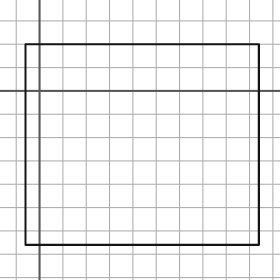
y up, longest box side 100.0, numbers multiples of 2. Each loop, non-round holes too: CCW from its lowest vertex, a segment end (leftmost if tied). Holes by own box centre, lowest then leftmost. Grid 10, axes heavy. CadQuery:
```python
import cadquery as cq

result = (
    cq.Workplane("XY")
    .moveTo(-6.0, -66.0)
    .lineTo(94.0, -66.0)
    .lineTo(94.0, 20.0)
    .lineTo(-6.0, 20.0)
    .close()
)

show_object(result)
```